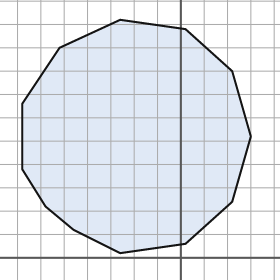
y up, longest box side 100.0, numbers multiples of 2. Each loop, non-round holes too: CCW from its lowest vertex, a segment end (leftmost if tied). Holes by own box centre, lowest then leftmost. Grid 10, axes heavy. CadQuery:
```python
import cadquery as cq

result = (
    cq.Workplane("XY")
    .moveTo(-26.0, 2.0)
    .lineTo(2.0, 6.0)
    .lineTo(22.0, 24.0)
    .lineTo(30.0, 52.0)
    .lineTo(22.0, 80.0)
    .lineTo(2.0, 98.0)
    .lineTo(-26.0, 102.0)
    .lineTo(-52.0, 90.0)
    .lineTo(-68.0, 66.0)
    .lineTo(-68.0, 38.0)
    .lineTo(-58.0, 22.0)
    .lineTo(-46.0, 12.0)
    .close()
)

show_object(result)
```